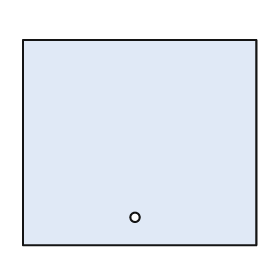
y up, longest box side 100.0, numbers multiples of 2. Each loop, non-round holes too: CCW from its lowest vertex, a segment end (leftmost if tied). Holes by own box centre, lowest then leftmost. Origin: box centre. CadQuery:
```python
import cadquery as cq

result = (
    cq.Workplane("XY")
    .moveTo(-50.0, -44.0)
    .lineTo(50.0, -44.0)
    .lineTo(50.0, 44.0)
    .lineTo(-50.0, 44.0)
    .close()
    .moveTo(-2.0, -32.0)
    .circle(2.0)
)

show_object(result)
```